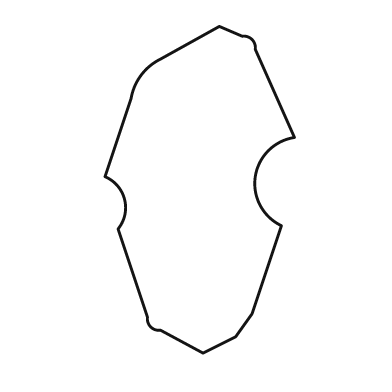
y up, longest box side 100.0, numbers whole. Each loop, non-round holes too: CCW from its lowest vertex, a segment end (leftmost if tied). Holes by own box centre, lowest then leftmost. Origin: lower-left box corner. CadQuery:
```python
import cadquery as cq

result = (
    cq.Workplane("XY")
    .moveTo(30.0, 0.0)
    .lineTo(40.0, 5.0)
    .lineTo(45.0, 12.0)
    .lineTo(54.0, 39.0)
    .threePointArc((46.0, 54.0), (58.0, 66.0))
    .lineTo(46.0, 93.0)
    .threePointArc((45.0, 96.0), (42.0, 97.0))
    .lineTo(35.0, 100.0)
    .lineTo(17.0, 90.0)
    .threePointArc((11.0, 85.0), (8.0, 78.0))
    .lineTo(0.0, 54.0)
    .threePointArc((6.0, 47.0), (4.0, 38.0))
    .lineTo(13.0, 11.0)
    .threePointArc((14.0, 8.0), (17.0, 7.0))
    .close()
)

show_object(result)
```